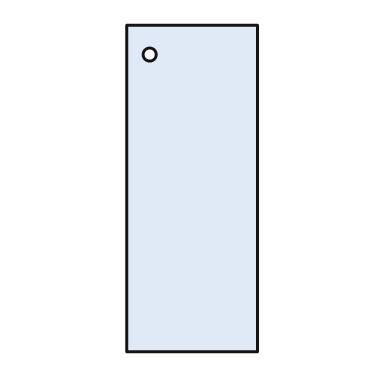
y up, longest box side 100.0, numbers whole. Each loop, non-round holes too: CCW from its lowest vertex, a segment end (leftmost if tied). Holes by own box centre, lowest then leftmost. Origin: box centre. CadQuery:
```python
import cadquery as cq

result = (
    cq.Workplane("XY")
    .moveTo(-20.0, -50.0)
    .lineTo(20.0, -50.0)
    .lineTo(20.0, 50.0)
    .lineTo(-20.0, 50.0)
    .close()
    .moveTo(-13.0, 41.0)
    .circle(2.0)
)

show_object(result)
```